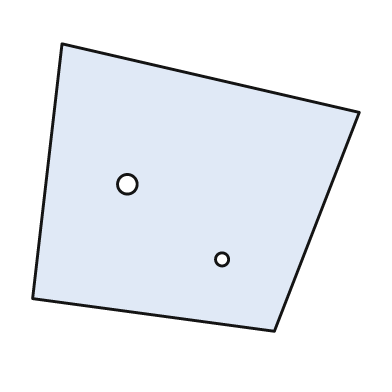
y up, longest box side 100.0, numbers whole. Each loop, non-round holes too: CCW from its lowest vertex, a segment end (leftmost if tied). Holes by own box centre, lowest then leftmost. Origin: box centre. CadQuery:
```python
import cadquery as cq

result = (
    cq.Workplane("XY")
    .moveTo(24.0, -44.0)
    .lineTo(50.0, 23.0)
    .lineTo(-41.0, 44.0)
    .lineTo(-50.0, -34.0)
    .close()
    .moveTo(8.0, -22.0)
    .circle(2.0)
    .moveTo(-21.0, 1.0)
    .circle(3.0)
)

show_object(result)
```